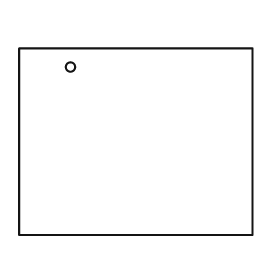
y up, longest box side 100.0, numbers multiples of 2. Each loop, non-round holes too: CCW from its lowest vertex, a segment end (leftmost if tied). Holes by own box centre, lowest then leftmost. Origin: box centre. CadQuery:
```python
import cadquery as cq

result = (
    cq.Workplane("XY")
    .moveTo(-50.0, -40.0)
    .lineTo(50.0, -40.0)
    .lineTo(50.0, 40.0)
    .lineTo(-50.0, 40.0)
    .close()
    .moveTo(-28.0, 32.0)
    .circle(2.0)
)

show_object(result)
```